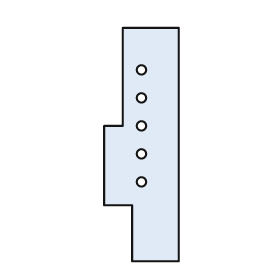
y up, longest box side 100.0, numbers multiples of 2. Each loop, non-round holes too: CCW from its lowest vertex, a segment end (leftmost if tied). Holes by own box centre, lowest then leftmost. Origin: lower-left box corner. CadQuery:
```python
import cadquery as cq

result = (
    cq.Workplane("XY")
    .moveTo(12.0, 0.0)
    .lineTo(32.0, 0.0)
    .lineTo(32.0, 100.0)
    .lineTo(8.0, 100.0)
    .lineTo(8.0, 58.0)
    .lineTo(0.0, 58.0)
    .lineTo(0.0, 24.0)
    .lineTo(12.0, 24.0)
    .close()
    .moveTo(16.0, 34.0)
    .circle(2.0)
    .moveTo(16.0, 46.0)
    .circle(2.0)
    .moveTo(16.0, 58.0)
    .circle(2.0)
    .moveTo(16.0, 70.0)
    .circle(2.0)
    .moveTo(16.0, 82.0)
    .circle(2.0)
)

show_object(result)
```